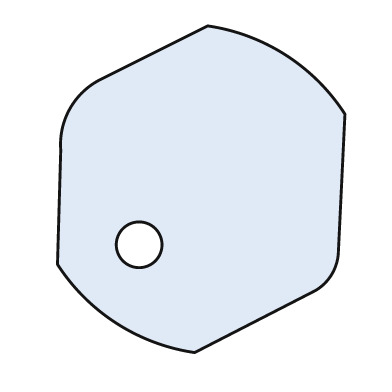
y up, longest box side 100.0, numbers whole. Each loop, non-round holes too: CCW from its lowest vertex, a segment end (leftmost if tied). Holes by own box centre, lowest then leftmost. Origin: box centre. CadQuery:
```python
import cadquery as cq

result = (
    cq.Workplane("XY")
    .moveTo(-2.0, -50.0)
    .lineTo(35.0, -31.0)
    .threePointArc((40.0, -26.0), (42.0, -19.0))
    .lineTo(44.0, 23.0)
    .threePointArc((26.0, 41.0), (2.0, 50.0))
    .lineTo(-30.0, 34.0)
    .threePointArc((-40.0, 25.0), (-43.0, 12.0))
    .lineTo(-44.0, -23.0)
    .threePointArc((-26.0, -41.0), (-2.0, -50.0))
    .close()
    .moveTo(-19.0, -17.0)
    .circle(7.0)
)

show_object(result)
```